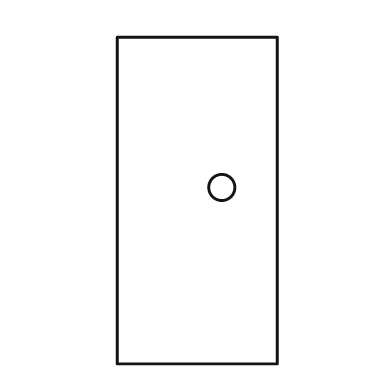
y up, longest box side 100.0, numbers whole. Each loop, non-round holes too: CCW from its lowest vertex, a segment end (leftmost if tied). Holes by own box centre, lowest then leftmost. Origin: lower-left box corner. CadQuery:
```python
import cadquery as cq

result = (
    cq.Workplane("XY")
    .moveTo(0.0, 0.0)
    .lineTo(49.0, 0.0)
    .lineTo(49.0, 100.0)
    .lineTo(0.0, 100.0)
    .close()
    .moveTo(32.0, 54.0)
    .circle(4.0)
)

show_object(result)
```